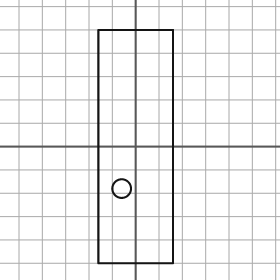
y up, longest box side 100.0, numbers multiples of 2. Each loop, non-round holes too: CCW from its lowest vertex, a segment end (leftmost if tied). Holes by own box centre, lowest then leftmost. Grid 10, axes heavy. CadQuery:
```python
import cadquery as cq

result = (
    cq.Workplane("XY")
    .moveTo(-16.0, -50.0)
    .lineTo(16.0, -50.0)
    .lineTo(16.0, 50.0)
    .lineTo(-16.0, 50.0)
    .close()
    .moveTo(-6.0, -18.0)
    .circle(4.0)
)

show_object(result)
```